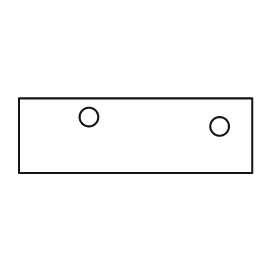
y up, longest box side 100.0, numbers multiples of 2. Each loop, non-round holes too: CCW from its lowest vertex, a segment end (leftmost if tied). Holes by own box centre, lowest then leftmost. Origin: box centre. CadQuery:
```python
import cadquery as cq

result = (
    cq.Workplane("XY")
    .moveTo(-50.0, -16.0)
    .lineTo(50.0, -16.0)
    .lineTo(50.0, 16.0)
    .lineTo(-50.0, 16.0)
    .close()
    .moveTo(36.0, 4.0)
    .circle(4.0)
    .moveTo(-20.0, 8.0)
    .circle(4.0)
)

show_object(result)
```